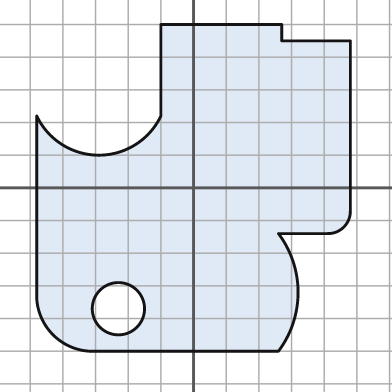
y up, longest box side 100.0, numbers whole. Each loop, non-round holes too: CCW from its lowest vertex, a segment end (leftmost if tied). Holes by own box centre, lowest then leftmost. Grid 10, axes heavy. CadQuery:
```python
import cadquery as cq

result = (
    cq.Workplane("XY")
    .moveTo(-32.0, -50.0)
    .lineTo(26.0, -50.0)
    .threePointArc((32.0, -32.0), (26.0, -14.0))
    .lineTo(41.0, -14.0)
    .threePointArc((46.0, -12.0), (48.0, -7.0))
    .lineTo(48.0, 45.0)
    .lineTo(27.0, 45.0)
    .lineTo(27.0, 50.0)
    .lineTo(-10.0, 50.0)
    .lineTo(-10.0, 22.0)
    .threePointArc((-29.0, 10.0), (-48.0, 22.0))
    .lineTo(-48.0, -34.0)
    .threePointArc((-43.0, -45.0), (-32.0, -50.0))
    .close()
    .moveTo(-23.0, -37.0)
    .circle(8.0)
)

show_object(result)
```